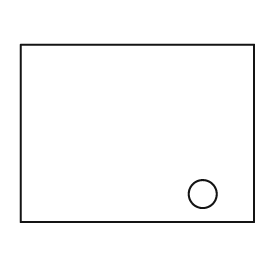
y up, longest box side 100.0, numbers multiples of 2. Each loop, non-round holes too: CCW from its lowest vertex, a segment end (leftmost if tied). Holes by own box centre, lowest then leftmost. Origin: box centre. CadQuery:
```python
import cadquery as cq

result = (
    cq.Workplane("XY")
    .moveTo(-50.0, -38.0)
    .lineTo(50.0, -38.0)
    .lineTo(50.0, 38.0)
    .lineTo(-50.0, 38.0)
    .close()
    .moveTo(28.0, -26.0)
    .circle(6.0)
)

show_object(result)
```